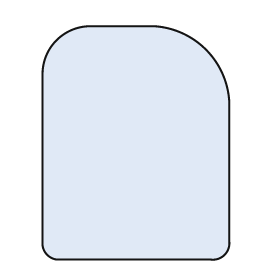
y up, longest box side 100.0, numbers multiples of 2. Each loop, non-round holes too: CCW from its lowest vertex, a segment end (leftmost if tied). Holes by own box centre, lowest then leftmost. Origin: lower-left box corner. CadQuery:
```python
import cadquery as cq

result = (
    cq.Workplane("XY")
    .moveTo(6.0, 0.0)
    .lineTo(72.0, 0.0)
    .threePointArc((78.0, 2.0), (80.0, 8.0))
    .lineTo(80.0, 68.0)
    .threePointArc((70.0, 90.0), (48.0, 100.0))
    .lineTo(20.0, 100.0)
    .threePointArc((6.0, 94.0), (0.0, 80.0))
    .lineTo(0.0, 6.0)
    .threePointArc((2.0, 2.0), (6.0, 0.0))
    .close()
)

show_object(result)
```